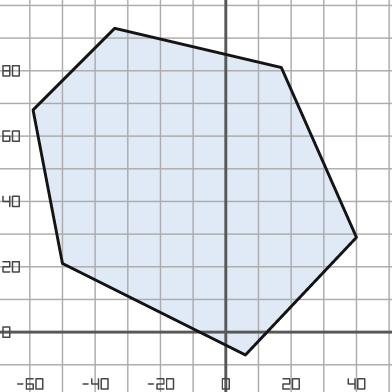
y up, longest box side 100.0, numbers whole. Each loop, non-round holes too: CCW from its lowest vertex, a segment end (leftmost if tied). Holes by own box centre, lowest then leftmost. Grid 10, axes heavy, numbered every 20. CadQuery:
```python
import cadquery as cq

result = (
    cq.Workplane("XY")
    .moveTo(6.0, -7.0)
    .lineTo(40.0, 29.0)
    .lineTo(17.0, 81.0)
    .lineTo(-34.0, 93.0)
    .lineTo(-59.0, 68.0)
    .lineTo(-50.0, 21.0)
    .close()
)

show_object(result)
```